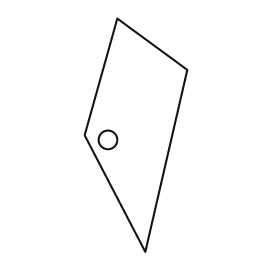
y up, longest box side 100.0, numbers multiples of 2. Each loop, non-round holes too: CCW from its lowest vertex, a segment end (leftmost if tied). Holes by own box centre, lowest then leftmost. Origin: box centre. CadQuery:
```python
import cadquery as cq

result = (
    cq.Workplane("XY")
    .moveTo(4.0, -50.0)
    .lineTo(22.0, 28.0)
    .lineTo(-8.0, 50.0)
    .lineTo(-22.0, 0.0)
    .close()
    .moveTo(-12.0, -2.0)
    .circle(4.0)
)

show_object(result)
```